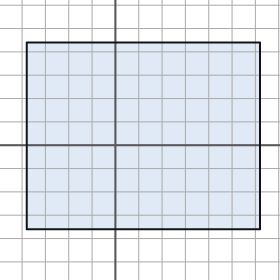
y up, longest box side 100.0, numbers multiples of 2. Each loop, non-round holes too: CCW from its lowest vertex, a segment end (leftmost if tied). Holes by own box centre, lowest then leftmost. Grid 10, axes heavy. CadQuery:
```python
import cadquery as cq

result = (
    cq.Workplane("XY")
    .moveTo(-38.0, -36.0)
    .lineTo(62.0, -36.0)
    .lineTo(62.0, 44.0)
    .lineTo(-38.0, 44.0)
    .close()
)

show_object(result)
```